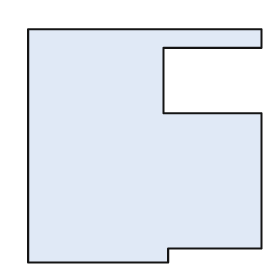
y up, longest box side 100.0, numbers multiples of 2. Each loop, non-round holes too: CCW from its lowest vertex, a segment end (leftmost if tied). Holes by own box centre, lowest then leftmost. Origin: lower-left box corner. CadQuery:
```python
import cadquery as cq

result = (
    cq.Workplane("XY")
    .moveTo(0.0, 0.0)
    .lineTo(60.0, 0.0)
    .lineTo(60.0, 6.0)
    .lineTo(100.0, 6.0)
    .lineTo(100.0, 64.0)
    .lineTo(58.0, 64.0)
    .lineTo(58.0, 92.0)
    .lineTo(100.0, 92.0)
    .lineTo(100.0, 100.0)
    .lineTo(0.0, 100.0)
    .close()
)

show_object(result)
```